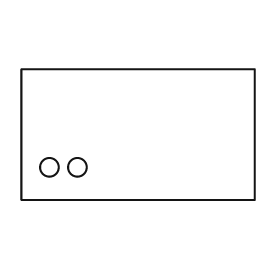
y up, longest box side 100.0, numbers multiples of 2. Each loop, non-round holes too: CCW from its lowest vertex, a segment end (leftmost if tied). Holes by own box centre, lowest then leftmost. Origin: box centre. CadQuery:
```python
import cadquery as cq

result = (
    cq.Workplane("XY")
    .moveTo(-50.0, -28.0)
    .lineTo(50.0, -28.0)
    .lineTo(50.0, 28.0)
    .lineTo(-50.0, 28.0)
    .close()
    .moveTo(-38.0, -14.0)
    .circle(4.0)
    .moveTo(-26.0, -14.0)
    .circle(4.0)
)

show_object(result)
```